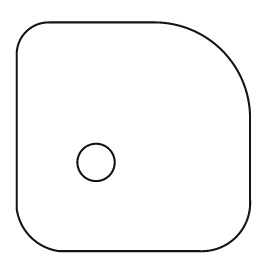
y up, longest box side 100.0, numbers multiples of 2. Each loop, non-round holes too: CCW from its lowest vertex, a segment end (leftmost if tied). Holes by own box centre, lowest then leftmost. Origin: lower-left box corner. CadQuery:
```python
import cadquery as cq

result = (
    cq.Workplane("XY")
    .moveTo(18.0, 0.0)
    .lineTo(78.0, 0.0)
    .threePointArc((94.0, 6.0), (100.0, 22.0))
    .lineTo(100.0, 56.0)
    .threePointArc((88.0, 86.0), (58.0, 98.0))
    .lineTo(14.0, 98.0)
    .threePointArc((4.0, 94.0), (0.0, 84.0))
    .lineTo(0.0, 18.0)
    .threePointArc((6.0, 6.0), (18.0, 0.0))
    .close()
    .moveTo(34.0, 38.0)
    .circle(8.0)
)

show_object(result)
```